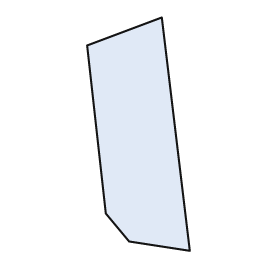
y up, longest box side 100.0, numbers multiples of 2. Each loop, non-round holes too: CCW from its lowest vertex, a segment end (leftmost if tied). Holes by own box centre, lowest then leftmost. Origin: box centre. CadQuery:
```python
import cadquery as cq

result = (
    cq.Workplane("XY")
    .moveTo(22.0, -50.0)
    .lineTo(10.0, 50.0)
    .lineTo(-22.0, 38.0)
    .lineTo(-14.0, -34.0)
    .lineTo(-4.0, -46.0)
    .close()
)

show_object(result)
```